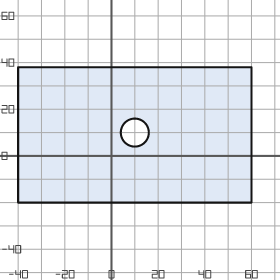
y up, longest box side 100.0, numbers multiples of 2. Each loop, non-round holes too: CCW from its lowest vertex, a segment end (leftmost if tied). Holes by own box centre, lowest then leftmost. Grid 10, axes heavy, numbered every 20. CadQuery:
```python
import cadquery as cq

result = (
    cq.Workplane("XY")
    .moveTo(-40.0, -20.0)
    .lineTo(60.0, -20.0)
    .lineTo(60.0, 38.0)
    .lineTo(-40.0, 38.0)
    .close()
    .moveTo(10.0, 10.0)
    .circle(6.0)
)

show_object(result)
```